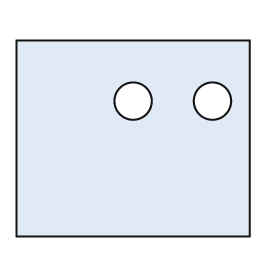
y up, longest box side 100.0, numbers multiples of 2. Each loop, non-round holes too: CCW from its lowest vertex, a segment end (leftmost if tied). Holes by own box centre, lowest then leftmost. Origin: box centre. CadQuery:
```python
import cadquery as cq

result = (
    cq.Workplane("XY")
    .moveTo(-50.0, -42.0)
    .lineTo(50.0, -42.0)
    .lineTo(50.0, 42.0)
    .lineTo(-50.0, 42.0)
    .close()
    .moveTo(0.0, 16.0)
    .circle(8.0)
    .moveTo(34.0, 16.0)
    .circle(8.0)
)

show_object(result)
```